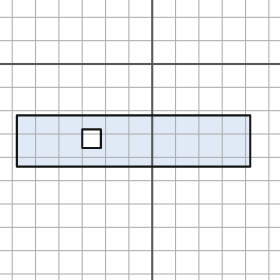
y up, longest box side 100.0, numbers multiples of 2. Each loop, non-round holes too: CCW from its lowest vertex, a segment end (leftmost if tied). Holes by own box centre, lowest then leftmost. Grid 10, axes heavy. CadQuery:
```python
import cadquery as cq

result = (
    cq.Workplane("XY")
    .moveTo(-58.0, -44.0)
    .lineTo(42.0, -44.0)
    .lineTo(42.0, -22.0)
    .lineTo(-58.0, -22.0)
    .close()
    .moveTo(-30.0, -36.0)
    .lineTo(-22.0, -36.0)
    .lineTo(-22.0, -28.0)
    .lineTo(-30.0, -28.0)
    .close()
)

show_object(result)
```